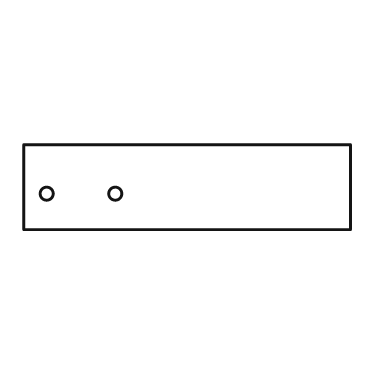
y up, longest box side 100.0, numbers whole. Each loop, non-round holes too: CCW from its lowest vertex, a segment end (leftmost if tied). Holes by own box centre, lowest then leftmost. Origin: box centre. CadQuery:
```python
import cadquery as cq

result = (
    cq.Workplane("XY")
    .moveTo(-50.0, -13.0)
    .lineTo(50.0, -13.0)
    .lineTo(50.0, 13.0)
    .lineTo(-50.0, 13.0)
    .close()
    .moveTo(-43.0, -2.0)
    .circle(2.0)
    .moveTo(-22.0, -2.0)
    .circle(2.0)
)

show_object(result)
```